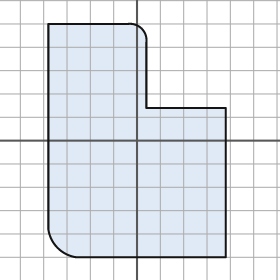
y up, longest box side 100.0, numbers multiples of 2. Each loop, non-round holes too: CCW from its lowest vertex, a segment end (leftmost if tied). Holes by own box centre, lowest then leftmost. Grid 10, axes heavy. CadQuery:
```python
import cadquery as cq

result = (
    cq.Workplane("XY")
    .moveTo(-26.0, -50.0)
    .lineTo(38.0, -50.0)
    .lineTo(38.0, 14.0)
    .lineTo(4.0, 14.0)
    .lineTo(4.0, 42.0)
    .threePointArc((2.0, 48.0), (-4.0, 50.0))
    .lineTo(-38.0, 50.0)
    .lineTo(-38.0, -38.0)
    .threePointArc((-34.0, -46.0), (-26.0, -50.0))
    .close()
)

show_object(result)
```